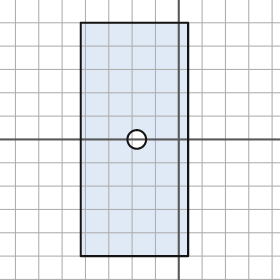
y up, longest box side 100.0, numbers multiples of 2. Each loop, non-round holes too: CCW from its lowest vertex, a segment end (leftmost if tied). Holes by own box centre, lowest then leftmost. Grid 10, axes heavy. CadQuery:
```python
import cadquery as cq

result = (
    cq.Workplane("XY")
    .moveTo(-42.0, -50.0)
    .lineTo(4.0, -50.0)
    .lineTo(4.0, 50.0)
    .lineTo(-42.0, 50.0)
    .close()
    .moveTo(-18.0, 0.0)
    .circle(4.0)
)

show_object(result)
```